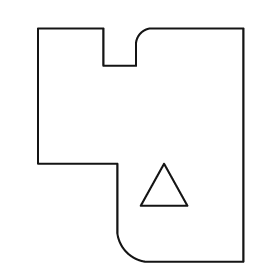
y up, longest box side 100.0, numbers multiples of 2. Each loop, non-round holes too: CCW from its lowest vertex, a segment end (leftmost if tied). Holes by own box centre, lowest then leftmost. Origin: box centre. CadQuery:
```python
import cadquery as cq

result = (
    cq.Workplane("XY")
    .moveTo(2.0, -50.0)
    .lineTo(44.0, -50.0)
    .lineTo(44.0, 50.0)
    .lineTo(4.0, 50.0)
    .threePointArc((0.0, 48.0), (-2.0, 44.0))
    .lineTo(-2.0, 34.0)
    .lineTo(-16.0, 34.0)
    .lineTo(-16.0, 50.0)
    .lineTo(-44.0, 50.0)
    .lineTo(-44.0, -8.0)
    .lineTo(-10.0, -8.0)
    .lineTo(-10.0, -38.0)
    .threePointArc((-6.0, -46.0), (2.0, -50.0))
    .close()
    .moveTo(0.0, -26.0)
    .lineTo(20.0, -26.0)
    .lineTo(10.0, -8.0)
    .close()
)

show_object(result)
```